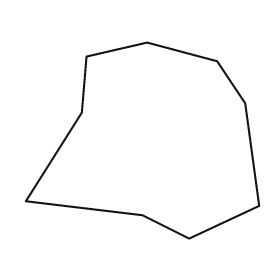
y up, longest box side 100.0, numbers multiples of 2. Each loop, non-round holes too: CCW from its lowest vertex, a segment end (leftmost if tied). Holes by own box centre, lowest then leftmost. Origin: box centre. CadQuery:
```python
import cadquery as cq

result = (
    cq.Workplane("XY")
    .moveTo(20.0, -42.0)
    .lineTo(50.0, -28.0)
    .lineTo(44.0, 16.0)
    .lineTo(32.0, 34.0)
    .lineTo(2.0, 42.0)
    .lineTo(-24.0, 36.0)
    .lineTo(-26.0, 12.0)
    .lineTo(-50.0, -26.0)
    .lineTo(0.0, -32.0)
    .close()
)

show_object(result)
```